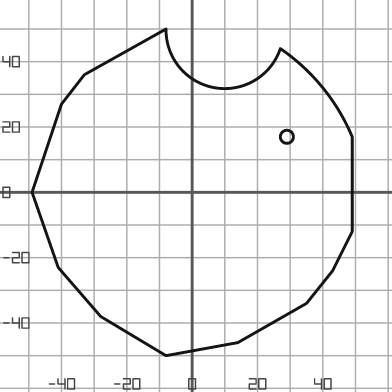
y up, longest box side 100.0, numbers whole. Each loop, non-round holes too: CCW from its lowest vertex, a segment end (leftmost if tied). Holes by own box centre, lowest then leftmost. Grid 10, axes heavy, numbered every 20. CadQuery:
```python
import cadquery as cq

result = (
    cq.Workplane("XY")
    .moveTo(-8.0, -50.0)
    .lineTo(14.0, -46.0)
    .lineTo(35.0, -34.0)
    .lineTo(43.0, -24.0)
    .lineTo(49.0, -12.0)
    .lineTo(49.0, 17.0)
    .threePointArc((40.0, 32.0), (27.0, 44.0))
    .threePointArc((7.0, 32.0), (-8.0, 50.0))
    .lineTo(-33.0, 36.0)
    .lineTo(-40.0, 27.0)
    .lineTo(-49.0, 0.0)
    .lineTo(-41.0, -23.0)
    .lineTo(-28.0, -38.0)
    .close()
    .moveTo(29.0, 17.0)
    .circle(2.0)
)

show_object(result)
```